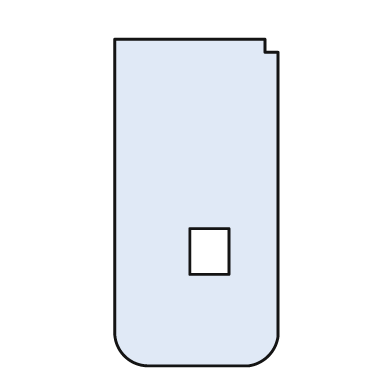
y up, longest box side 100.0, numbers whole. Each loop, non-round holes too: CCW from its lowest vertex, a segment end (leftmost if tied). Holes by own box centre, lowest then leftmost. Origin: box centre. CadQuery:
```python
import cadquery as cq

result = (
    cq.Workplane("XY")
    .moveTo(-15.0, -50.0)
    .lineTo(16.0, -50.0)
    .threePointArc((22.0, -47.0), (25.0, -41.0))
    .lineTo(25.0, 46.0)
    .lineTo(21.0, 46.0)
    .lineTo(21.0, 50.0)
    .lineTo(-25.0, 50.0)
    .lineTo(-25.0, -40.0)
    .threePointArc((-22.0, -47.0), (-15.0, -50.0))
    .close()
    .moveTo(-2.0, -22.0)
    .lineTo(10.0, -22.0)
    .lineTo(10.0, -8.0)
    .lineTo(-2.0, -8.0)
    .close()
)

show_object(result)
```